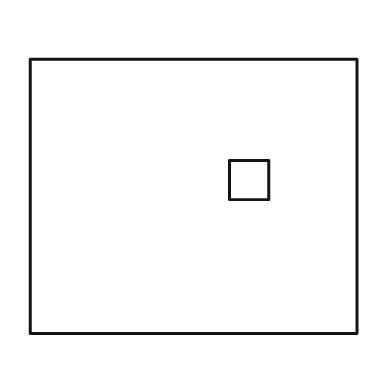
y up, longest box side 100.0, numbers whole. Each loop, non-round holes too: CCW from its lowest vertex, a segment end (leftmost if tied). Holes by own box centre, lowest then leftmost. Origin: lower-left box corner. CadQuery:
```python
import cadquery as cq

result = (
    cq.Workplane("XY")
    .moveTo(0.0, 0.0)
    .lineTo(100.0, 0.0)
    .lineTo(100.0, 84.0)
    .lineTo(0.0, 84.0)
    .close()
    .moveTo(61.0, 41.0)
    .lineTo(73.0, 41.0)
    .lineTo(73.0, 53.0)
    .lineTo(61.0, 53.0)
    .close()
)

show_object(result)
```